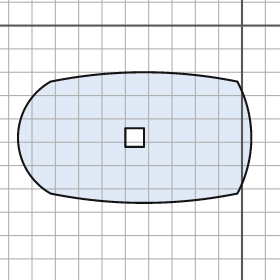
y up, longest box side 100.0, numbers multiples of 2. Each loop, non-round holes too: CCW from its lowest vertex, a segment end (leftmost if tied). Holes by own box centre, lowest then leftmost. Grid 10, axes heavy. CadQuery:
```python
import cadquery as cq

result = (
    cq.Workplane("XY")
    .moveTo(-82.0, -72.0)
    .threePointArc((-42.0, -76.0), (-2.0, -72.0))
    .threePointArc((4.0, -48.0), (-2.0, -24.0))
    .threePointArc((-42.0, -20.0), (-82.0, -24.0))
    .threePointArc((-96.0, -48.0), (-82.0, -72.0))
    .close()
    .moveTo(-50.0, -52.0)
    .lineTo(-42.0, -52.0)
    .lineTo(-42.0, -44.0)
    .lineTo(-50.0, -44.0)
    .close()
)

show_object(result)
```